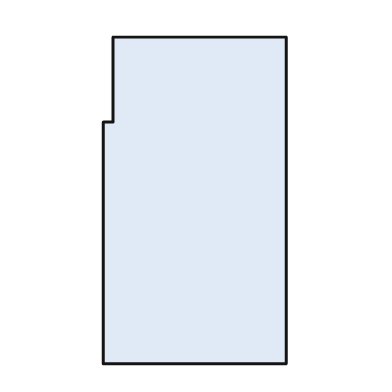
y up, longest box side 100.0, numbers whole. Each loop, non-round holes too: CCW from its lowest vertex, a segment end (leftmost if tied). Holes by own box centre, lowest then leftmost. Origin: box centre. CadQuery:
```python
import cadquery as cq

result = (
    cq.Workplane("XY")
    .moveTo(-28.0, -50.0)
    .lineTo(28.0, -50.0)
    .lineTo(28.0, 50.0)
    .lineTo(-25.0, 50.0)
    .lineTo(-25.0, 24.0)
    .lineTo(-28.0, 24.0)
    .close()
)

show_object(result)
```